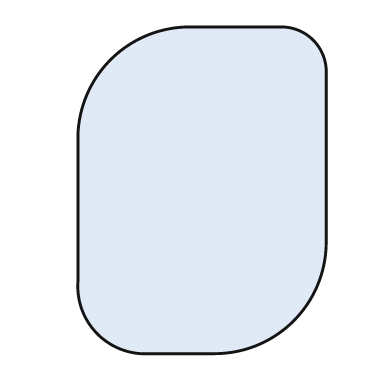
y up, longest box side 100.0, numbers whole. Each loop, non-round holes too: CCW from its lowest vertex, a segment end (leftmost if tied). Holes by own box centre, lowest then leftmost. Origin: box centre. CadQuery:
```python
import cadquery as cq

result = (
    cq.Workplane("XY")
    .moveTo(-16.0, -50.0)
    .lineTo(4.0, -50.0)
    .threePointArc((28.0, -40.0), (38.0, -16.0))
    .lineTo(38.0, 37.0)
    .threePointArc((34.0, 46.0), (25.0, 50.0))
    .lineTo(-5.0, 50.0)
    .threePointArc((-28.0, 40.0), (-38.0, 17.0))
    .lineTo(-38.0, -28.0)
    .threePointArc((-32.0, -44.0), (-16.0, -50.0))
    .close()
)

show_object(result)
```